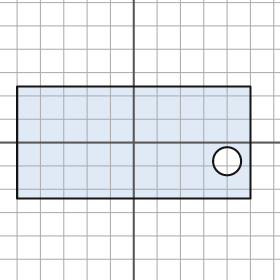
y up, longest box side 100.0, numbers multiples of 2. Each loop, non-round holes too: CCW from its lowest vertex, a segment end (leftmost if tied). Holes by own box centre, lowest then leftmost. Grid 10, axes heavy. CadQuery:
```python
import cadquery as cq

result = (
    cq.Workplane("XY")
    .moveTo(-50.0, -24.0)
    .lineTo(50.0, -24.0)
    .lineTo(50.0, 24.0)
    .lineTo(-50.0, 24.0)
    .close()
    .moveTo(40.0, -8.0)
    .circle(6.0)
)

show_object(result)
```